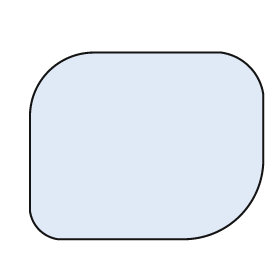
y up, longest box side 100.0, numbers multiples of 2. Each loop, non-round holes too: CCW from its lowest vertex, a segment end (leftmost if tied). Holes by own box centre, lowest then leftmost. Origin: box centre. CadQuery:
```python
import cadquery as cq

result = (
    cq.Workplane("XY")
    .moveTo(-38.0, -40.0)
    .lineTo(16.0, -40.0)
    .threePointArc((40.0, -30.0), (50.0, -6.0))
    .lineTo(50.0, 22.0)
    .threePointArc((44.0, 34.0), (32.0, 40.0))
    .lineTo(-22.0, 40.0)
    .threePointArc((-42.0, 32.0), (-50.0, 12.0))
    .lineTo(-50.0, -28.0)
    .threePointArc((-46.0, -36.0), (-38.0, -40.0))
    .close()
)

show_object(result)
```